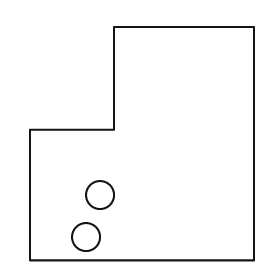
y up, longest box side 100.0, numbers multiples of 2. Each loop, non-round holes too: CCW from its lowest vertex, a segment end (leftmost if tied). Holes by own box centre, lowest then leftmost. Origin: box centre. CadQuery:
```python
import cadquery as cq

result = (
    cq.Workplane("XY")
    .moveTo(-48.0, -50.0)
    .lineTo(48.0, -50.0)
    .lineTo(48.0, 50.0)
    .lineTo(-12.0, 50.0)
    .lineTo(-12.0, 6.0)
    .lineTo(-48.0, 6.0)
    .close()
    .moveTo(-24.0, -40.0)
    .circle(6.0)
    .moveTo(-18.0, -22.0)
    .circle(6.0)
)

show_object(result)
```